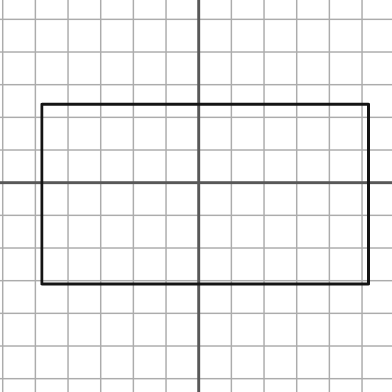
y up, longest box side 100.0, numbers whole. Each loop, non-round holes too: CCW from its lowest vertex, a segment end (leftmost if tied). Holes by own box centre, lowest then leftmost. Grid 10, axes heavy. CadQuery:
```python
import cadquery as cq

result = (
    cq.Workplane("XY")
    .moveTo(-48.0, -31.0)
    .lineTo(52.0, -31.0)
    .lineTo(52.0, 24.0)
    .lineTo(-48.0, 24.0)
    .close()
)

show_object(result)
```